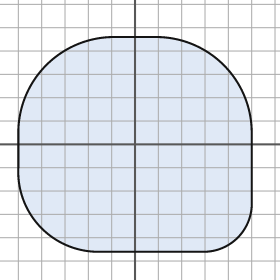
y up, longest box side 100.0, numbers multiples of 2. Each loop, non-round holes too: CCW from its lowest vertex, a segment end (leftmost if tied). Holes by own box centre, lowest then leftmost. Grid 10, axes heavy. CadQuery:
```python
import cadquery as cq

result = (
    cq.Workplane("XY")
    .moveTo(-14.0, -46.0)
    .lineTo(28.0, -46.0)
    .threePointArc((44.0, -40.0), (50.0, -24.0))
    .lineTo(50.0, 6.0)
    .threePointArc((38.0, 34.0), (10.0, 46.0))
    .lineTo(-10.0, 46.0)
    .threePointArc((-38.0, 34.0), (-50.0, 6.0))
    .lineTo(-50.0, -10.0)
    .threePointArc((-40.0, -36.0), (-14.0, -46.0))
    .close()
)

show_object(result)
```